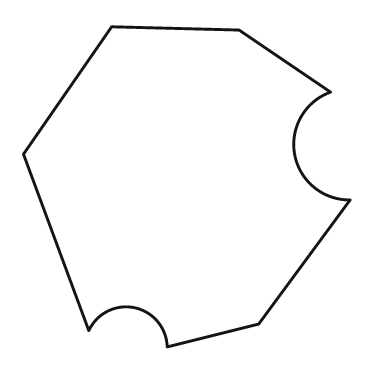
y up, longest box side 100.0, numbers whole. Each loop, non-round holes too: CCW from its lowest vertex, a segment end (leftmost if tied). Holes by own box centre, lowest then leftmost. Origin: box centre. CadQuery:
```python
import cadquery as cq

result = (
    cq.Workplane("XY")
    .moveTo(-6.0, -49.0)
    .lineTo(22.0, -42.0)
    .lineTo(50.0, -4.0)
    .threePointArc((33.0, 10.0), (44.0, 29.0))
    .lineTo(16.0, 48.0)
    .lineTo(-23.0, 49.0)
    .lineTo(-50.0, 10.0)
    .lineTo(-30.0, -44.0)
    .threePointArc((-16.0, -37.0), (-6.0, -49.0))
    .close()
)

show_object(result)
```